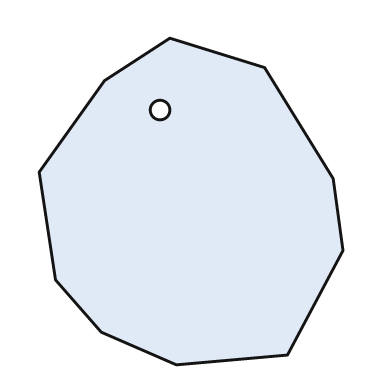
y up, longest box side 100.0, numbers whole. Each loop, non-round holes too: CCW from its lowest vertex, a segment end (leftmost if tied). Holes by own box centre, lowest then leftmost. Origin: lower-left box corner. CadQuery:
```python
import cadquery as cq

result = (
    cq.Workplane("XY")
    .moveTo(42.0, 0.0)
    .lineTo(76.0, 3.0)
    .lineTo(93.0, 35.0)
    .lineTo(90.0, 57.0)
    .lineTo(69.0, 91.0)
    .lineTo(40.0, 100.0)
    .lineTo(20.0, 87.0)
    .lineTo(0.0, 59.0)
    .lineTo(5.0, 26.0)
    .lineTo(19.0, 10.0)
    .close()
    .moveTo(37.0, 78.0)
    .circle(3.0)
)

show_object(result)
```